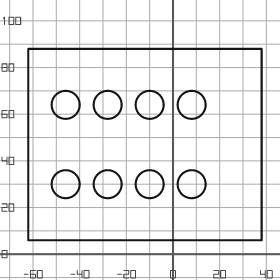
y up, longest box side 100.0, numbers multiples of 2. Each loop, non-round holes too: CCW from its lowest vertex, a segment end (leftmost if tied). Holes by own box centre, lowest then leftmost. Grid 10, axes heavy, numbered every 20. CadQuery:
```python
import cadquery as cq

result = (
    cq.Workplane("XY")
    .moveTo(-62.0, 6.0)
    .lineTo(38.0, 6.0)
    .lineTo(38.0, 88.0)
    .lineTo(-62.0, 88.0)
    .close()
    .moveTo(-46.0, 30.0)
    .circle(6.0)
    .moveTo(-28.0, 30.0)
    .circle(6.0)
    .moveTo(-10.0, 30.0)
    .circle(6.0)
    .moveTo(8.0, 30.0)
    .circle(6.0)
    .moveTo(-46.0, 64.0)
    .circle(6.0)
    .moveTo(-28.0, 64.0)
    .circle(6.0)
    .moveTo(-10.0, 64.0)
    .circle(6.0)
    .moveTo(8.0, 64.0)
    .circle(6.0)
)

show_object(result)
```